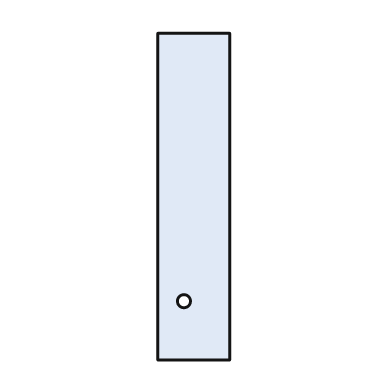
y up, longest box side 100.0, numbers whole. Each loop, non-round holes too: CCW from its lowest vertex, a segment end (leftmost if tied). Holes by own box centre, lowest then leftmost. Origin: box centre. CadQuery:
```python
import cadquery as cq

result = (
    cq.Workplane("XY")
    .moveTo(-11.0, -50.0)
    .lineTo(11.0, -50.0)
    .lineTo(11.0, 50.0)
    .lineTo(-11.0, 50.0)
    .close()
    .moveTo(-3.0, -32.0)
    .circle(2.0)
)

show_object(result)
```